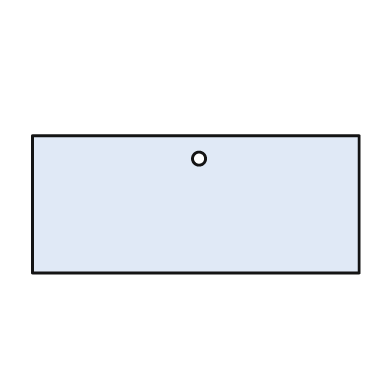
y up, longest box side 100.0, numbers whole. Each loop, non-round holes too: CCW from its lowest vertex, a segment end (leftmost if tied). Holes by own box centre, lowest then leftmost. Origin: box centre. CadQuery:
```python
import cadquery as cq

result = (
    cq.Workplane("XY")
    .moveTo(-50.0, -21.0)
    .lineTo(50.0, -21.0)
    .lineTo(50.0, 21.0)
    .lineTo(-50.0, 21.0)
    .close()
    .moveTo(1.0, 14.0)
    .circle(2.0)
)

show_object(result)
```